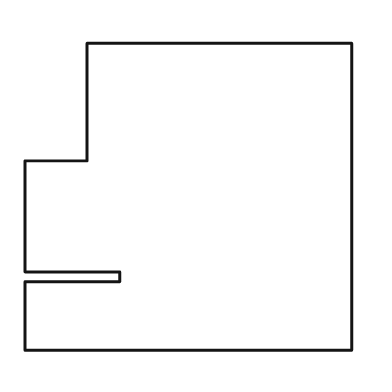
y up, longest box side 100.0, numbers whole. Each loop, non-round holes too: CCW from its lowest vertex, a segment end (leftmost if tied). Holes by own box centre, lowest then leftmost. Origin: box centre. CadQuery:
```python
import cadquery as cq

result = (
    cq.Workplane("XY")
    .moveTo(-50.0, -47.0)
    .lineTo(50.0, -47.0)
    .lineTo(50.0, 47.0)
    .lineTo(-31.0, 47.0)
    .lineTo(-31.0, 11.0)
    .lineTo(-50.0, 11.0)
    .lineTo(-50.0, -23.0)
    .lineTo(-21.0, -23.0)
    .lineTo(-21.0, -26.0)
    .lineTo(-50.0, -26.0)
    .close()
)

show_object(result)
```